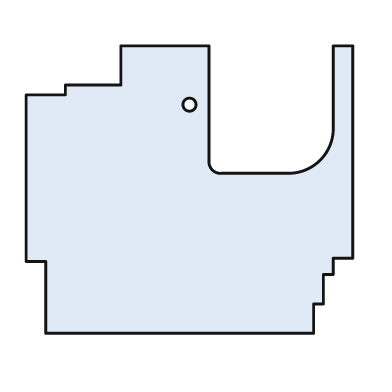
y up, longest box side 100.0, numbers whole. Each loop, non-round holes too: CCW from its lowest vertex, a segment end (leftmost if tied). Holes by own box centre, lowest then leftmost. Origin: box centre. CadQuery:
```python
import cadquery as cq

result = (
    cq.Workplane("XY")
    .moveTo(-44.0, -44.0)
    .lineTo(38.0, -44.0)
    .lineTo(38.0, -35.0)
    .lineTo(41.0, -35.0)
    .lineTo(41.0, -26.0)
    .lineTo(44.0, -26.0)
    .lineTo(44.0, -21.0)
    .lineTo(50.0, -21.0)
    .lineTo(50.0, 44.0)
    .lineTo(44.0, 44.0)
    .lineTo(44.0, 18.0)
    .threePointArc((40.0, 9.0), (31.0, 5.0))
    .lineTo(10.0, 5.0)
    .threePointArc((7.0, 6.0), (6.0, 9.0))
    .lineTo(6.0, 44.0)
    .lineTo(-21.0, 44.0)
    .lineTo(-21.0, 32.0)
    .lineTo(-38.0, 32.0)
    .lineTo(-38.0, 29.0)
    .lineTo(-50.0, 29.0)
    .lineTo(-50.0, -22.0)
    .lineTo(-44.0, -22.0)
    .close()
    .moveTo(0.0, 26.0)
    .circle(2.0)
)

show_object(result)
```